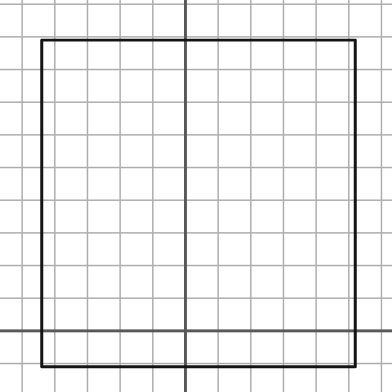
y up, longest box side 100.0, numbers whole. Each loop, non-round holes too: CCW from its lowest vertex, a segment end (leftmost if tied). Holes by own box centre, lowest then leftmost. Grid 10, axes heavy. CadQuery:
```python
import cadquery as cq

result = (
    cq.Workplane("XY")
    .moveTo(-44.0, -11.0)
    .lineTo(52.0, -11.0)
    .lineTo(52.0, 89.0)
    .lineTo(-44.0, 89.0)
    .close()
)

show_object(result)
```